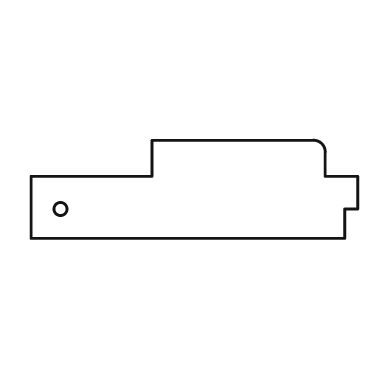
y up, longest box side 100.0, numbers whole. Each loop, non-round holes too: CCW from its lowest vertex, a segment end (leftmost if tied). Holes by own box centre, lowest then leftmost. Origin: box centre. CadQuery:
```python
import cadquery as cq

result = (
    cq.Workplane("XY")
    .moveTo(-50.0, -15.0)
    .lineTo(46.0, -15.0)
    .lineTo(46.0, -6.0)
    .lineTo(50.0, -6.0)
    .lineTo(50.0, 4.0)
    .lineTo(40.0, 4.0)
    .lineTo(40.0, 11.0)
    .threePointArc((39.0, 14.0), (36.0, 15.0))
    .lineTo(-13.0, 15.0)
    .lineTo(-13.0, 4.0)
    .lineTo(-50.0, 4.0)
    .close()
    .moveTo(-41.0, -6.0)
    .circle(2.0)
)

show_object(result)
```